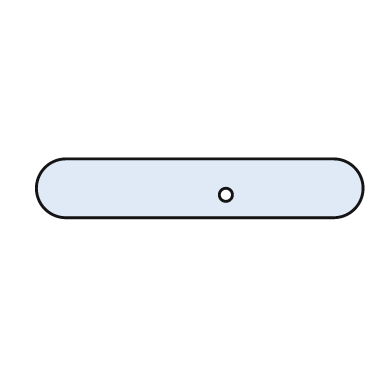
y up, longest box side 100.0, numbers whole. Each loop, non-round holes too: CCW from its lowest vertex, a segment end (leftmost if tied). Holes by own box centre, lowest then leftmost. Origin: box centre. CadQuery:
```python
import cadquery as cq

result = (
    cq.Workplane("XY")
    .moveTo(-41.0, -9.0)
    .lineTo(41.0, -9.0)
    .threePointArc((50.0, 0.0), (41.0, 9.0))
    .lineTo(-41.0, 9.0)
    .threePointArc((-50.0, 0.0), (-41.0, -9.0))
    .close()
    .moveTo(8.0, -2.0)
    .circle(2.0)
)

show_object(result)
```